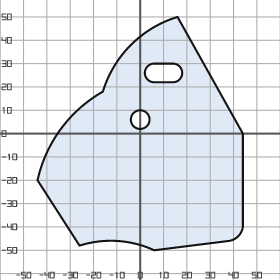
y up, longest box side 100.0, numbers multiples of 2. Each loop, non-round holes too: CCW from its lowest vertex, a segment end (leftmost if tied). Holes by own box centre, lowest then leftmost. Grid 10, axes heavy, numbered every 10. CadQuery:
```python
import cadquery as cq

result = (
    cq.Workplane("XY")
    .moveTo(6.0, -50.0)
    .lineTo(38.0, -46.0)
    .threePointArc((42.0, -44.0), (44.0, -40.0))
    .lineTo(44.0, 0.0)
    .lineTo(16.0, 50.0)
    .threePointArc((-4.0, 38.0), (-16.0, 18.0))
    .threePointArc((-34.0, 2.0), (-44.0, -20.0))
    .lineTo(-26.0, -48.0)
    .threePointArc((-10.0, -46.0), (6.0, -50.0))
    .close()
    .moveTo(0.0, 6.0)
    .circle(4.0)
    .moveTo(6.0, 22.0)
    .lineTo(14.0, 22.0)
    .threePointArc((18.0, 26.0), (14.0, 30.0))
    .lineTo(6.0, 30.0)
    .threePointArc((2.0, 26.0), (6.0, 22.0))
    .close()
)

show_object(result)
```